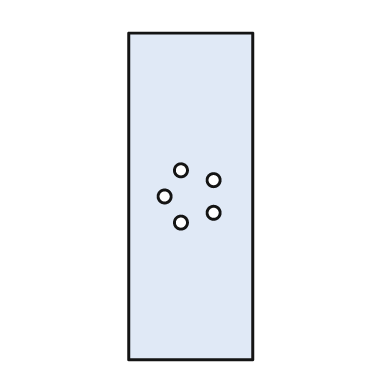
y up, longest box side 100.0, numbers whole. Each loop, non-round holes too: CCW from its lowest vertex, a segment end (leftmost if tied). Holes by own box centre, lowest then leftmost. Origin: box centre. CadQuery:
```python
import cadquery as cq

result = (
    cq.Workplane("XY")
    .moveTo(-19.0, -50.0)
    .lineTo(19.0, -50.0)
    .lineTo(19.0, 50.0)
    .lineTo(-19.0, 50.0)
    .close()
    .moveTo(-3.0, -8.0)
    .circle(2.0)
    .moveTo(7.0, -5.0)
    .circle(2.0)
    .moveTo(-8.0, 0.0)
    .circle(2.0)
    .moveTo(7.0, 5.0)
    .circle(2.0)
    .moveTo(-3.0, 8.0)
    .circle(2.0)
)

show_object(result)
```